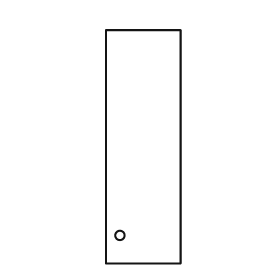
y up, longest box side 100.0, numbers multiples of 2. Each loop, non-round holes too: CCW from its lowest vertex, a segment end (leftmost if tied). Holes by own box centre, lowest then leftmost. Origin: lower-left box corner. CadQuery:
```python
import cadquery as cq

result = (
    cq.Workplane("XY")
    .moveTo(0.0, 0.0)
    .lineTo(32.0, 0.0)
    .lineTo(32.0, 100.0)
    .lineTo(0.0, 100.0)
    .close()
    .moveTo(6.0, 12.0)
    .circle(2.0)
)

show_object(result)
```